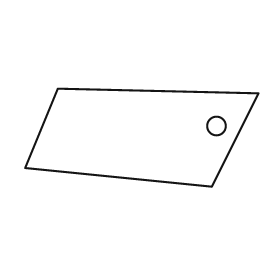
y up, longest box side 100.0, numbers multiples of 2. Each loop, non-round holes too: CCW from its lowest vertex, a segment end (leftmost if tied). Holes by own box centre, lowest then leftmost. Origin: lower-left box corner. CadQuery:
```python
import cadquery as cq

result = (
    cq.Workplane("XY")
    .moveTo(80.0, 0.0)
    .lineTo(100.0, 40.0)
    .lineTo(14.0, 42.0)
    .lineTo(0.0, 8.0)
    .close()
    .moveTo(82.0, 26.0)
    .circle(4.0)
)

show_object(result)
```